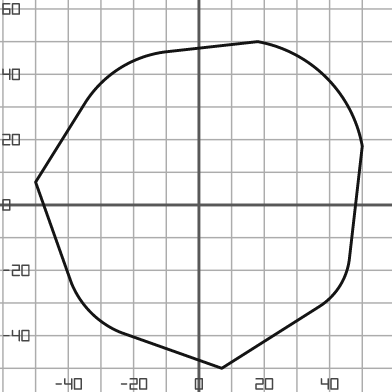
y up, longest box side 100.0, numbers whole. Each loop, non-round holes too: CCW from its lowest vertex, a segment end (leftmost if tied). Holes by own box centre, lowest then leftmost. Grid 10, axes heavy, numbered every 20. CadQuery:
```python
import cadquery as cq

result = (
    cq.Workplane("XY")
    .moveTo(7.0, -50.0)
    .lineTo(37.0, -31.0)
    .threePointArc((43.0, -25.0), (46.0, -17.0))
    .lineTo(50.0, 18.0)
    .threePointArc((39.0, 39.0), (18.0, 50.0))
    .lineTo(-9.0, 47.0)
    .threePointArc((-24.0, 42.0), (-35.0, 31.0))
    .lineTo(-50.0, 7.0)
    .lineTo(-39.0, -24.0)
    .threePointArc((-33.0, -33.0), (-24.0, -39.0))
    .close()
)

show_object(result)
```